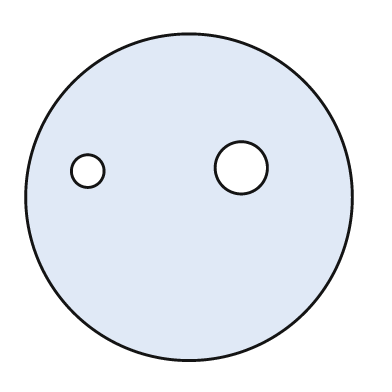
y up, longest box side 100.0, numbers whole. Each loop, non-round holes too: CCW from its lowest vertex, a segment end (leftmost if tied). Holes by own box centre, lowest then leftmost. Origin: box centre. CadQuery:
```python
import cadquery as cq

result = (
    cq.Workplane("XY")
    .moveTo(0.0, 0.0)
    .circle(50.0)
    .moveTo(-31.0, 8.0)
    .circle(5.0)
    .moveTo(16.0, 9.0)
    .circle(8.0)
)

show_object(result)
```